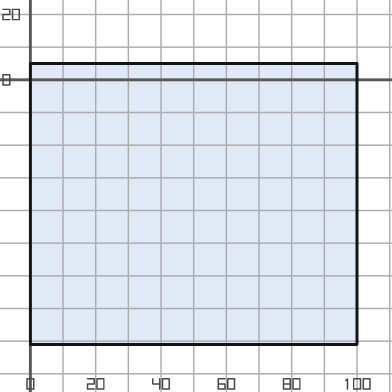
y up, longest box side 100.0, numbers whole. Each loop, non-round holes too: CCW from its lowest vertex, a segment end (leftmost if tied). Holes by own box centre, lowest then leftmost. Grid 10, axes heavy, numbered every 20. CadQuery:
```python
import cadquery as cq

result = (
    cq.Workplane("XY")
    .moveTo(0.0, -81.0)
    .lineTo(100.0, -81.0)
    .lineTo(100.0, 5.0)
    .lineTo(0.0, 5.0)
    .close()
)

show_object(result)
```